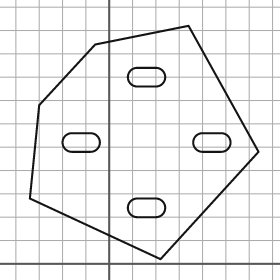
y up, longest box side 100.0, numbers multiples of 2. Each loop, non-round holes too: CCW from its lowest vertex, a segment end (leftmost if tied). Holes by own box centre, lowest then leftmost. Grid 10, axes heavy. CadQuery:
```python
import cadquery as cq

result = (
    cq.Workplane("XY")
    .moveTo(22.0, 2.0)
    .lineTo(64.0, 48.0)
    .lineTo(34.0, 102.0)
    .lineTo(-6.0, 94.0)
    .lineTo(-30.0, 68.0)
    .lineTo(-34.0, 28.0)
    .close()
    .moveTo(12.0, 20.0)
    .lineTo(20.0, 20.0)
    .threePointArc((24.0, 24.0), (20.0, 28.0))
    .lineTo(12.0, 28.0)
    .threePointArc((8.0, 24.0), (12.0, 20.0))
    .close()
    .moveTo(-16.0, 48.0)
    .lineTo(-8.0, 48.0)
    .threePointArc((-4.0, 52.0), (-8.0, 56.0))
    .lineTo(-16.0, 56.0)
    .threePointArc((-20.0, 52.0), (-16.0, 48.0))
    .close()
    .moveTo(40.0, 48.0)
    .lineTo(48.0, 48.0)
    .threePointArc((52.0, 52.0), (48.0, 56.0))
    .lineTo(40.0, 56.0)
    .threePointArc((36.0, 52.0), (40.0, 48.0))
    .close()
    .moveTo(12.0, 76.0)
    .lineTo(20.0, 76.0)
    .threePointArc((24.0, 80.0), (20.0, 84.0))
    .lineTo(12.0, 84.0)
    .threePointArc((8.0, 80.0), (12.0, 76.0))
    .close()
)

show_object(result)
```